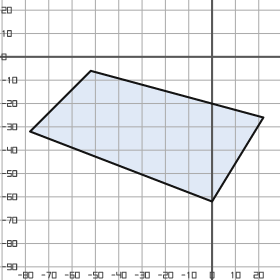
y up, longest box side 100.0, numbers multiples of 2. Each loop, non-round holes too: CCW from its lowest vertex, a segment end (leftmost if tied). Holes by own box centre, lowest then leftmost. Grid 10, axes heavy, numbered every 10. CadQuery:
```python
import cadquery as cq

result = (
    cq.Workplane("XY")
    .moveTo(0.0, -62.0)
    .lineTo(22.0, -26.0)
    .lineTo(-52.0, -6.0)
    .lineTo(-78.0, -32.0)
    .close()
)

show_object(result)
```